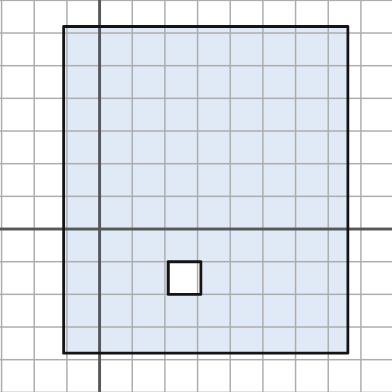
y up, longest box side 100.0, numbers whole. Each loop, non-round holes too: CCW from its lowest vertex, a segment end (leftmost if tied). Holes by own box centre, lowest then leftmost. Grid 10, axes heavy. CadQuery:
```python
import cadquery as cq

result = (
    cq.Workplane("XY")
    .moveTo(-11.0, -38.0)
    .lineTo(76.0, -38.0)
    .lineTo(76.0, 62.0)
    .lineTo(-11.0, 62.0)
    .close()
    .moveTo(21.0, -20.0)
    .lineTo(31.0, -20.0)
    .lineTo(31.0, -10.0)
    .lineTo(21.0, -10.0)
    .close()
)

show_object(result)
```